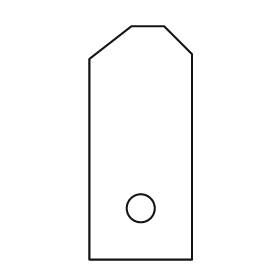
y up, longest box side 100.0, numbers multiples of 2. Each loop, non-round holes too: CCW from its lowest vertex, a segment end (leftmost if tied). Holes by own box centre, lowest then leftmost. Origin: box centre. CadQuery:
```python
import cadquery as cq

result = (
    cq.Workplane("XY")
    .moveTo(-22.0, -50.0)
    .lineTo(22.0, -50.0)
    .lineTo(22.0, 38.0)
    .lineTo(10.0, 50.0)
    .lineTo(-4.0, 50.0)
    .lineTo(-22.0, 36.0)
    .close()
    .moveTo(0.0, -28.0)
    .circle(6.0)
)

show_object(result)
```